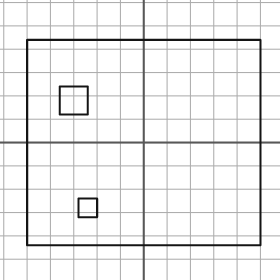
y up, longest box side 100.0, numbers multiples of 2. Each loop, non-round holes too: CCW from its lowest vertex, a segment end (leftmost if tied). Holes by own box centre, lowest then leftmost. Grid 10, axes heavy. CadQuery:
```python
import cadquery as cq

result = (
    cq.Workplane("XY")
    .moveTo(-50.0, -44.0)
    .lineTo(50.0, -44.0)
    .lineTo(50.0, 44.0)
    .lineTo(-50.0, 44.0)
    .close()
    .moveTo(-28.0, -32.0)
    .lineTo(-20.0, -32.0)
    .lineTo(-20.0, -24.0)
    .lineTo(-28.0, -24.0)
    .close()
    .moveTo(-36.0, 12.0)
    .lineTo(-24.0, 12.0)
    .lineTo(-24.0, 24.0)
    .lineTo(-36.0, 24.0)
    .close()
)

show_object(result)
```